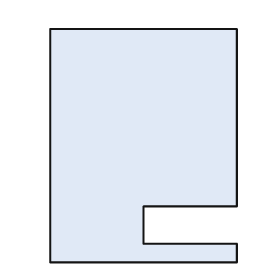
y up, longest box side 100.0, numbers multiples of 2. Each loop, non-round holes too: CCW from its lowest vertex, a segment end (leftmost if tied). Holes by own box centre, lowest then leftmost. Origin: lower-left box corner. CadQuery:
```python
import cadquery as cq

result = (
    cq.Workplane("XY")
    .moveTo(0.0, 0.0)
    .lineTo(80.0, 0.0)
    .lineTo(80.0, 8.0)
    .lineTo(40.0, 8.0)
    .lineTo(40.0, 24.0)
    .lineTo(80.0, 24.0)
    .lineTo(80.0, 100.0)
    .lineTo(0.0, 100.0)
    .close()
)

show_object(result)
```